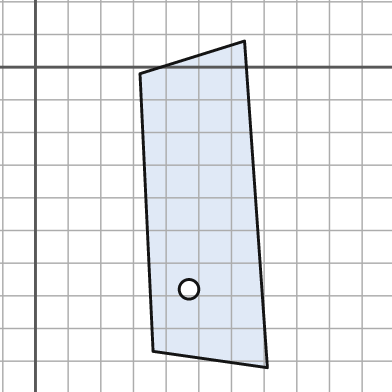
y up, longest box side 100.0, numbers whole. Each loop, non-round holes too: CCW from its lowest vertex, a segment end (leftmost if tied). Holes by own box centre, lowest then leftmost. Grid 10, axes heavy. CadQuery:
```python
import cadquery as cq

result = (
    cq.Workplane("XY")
    .moveTo(71.0, -92.0)
    .lineTo(64.0, 8.0)
    .lineTo(32.0, -2.0)
    .lineTo(36.0, -87.0)
    .close()
    .moveTo(47.0, -68.0)
    .circle(3.0)
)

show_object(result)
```